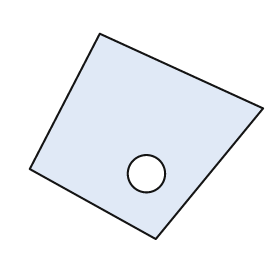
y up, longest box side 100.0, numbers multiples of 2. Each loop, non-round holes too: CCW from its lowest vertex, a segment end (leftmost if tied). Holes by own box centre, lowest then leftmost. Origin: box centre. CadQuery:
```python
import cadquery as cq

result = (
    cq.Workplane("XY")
    .moveTo(4.0, -44.0)
    .lineTo(50.0, 12.0)
    .lineTo(-20.0, 44.0)
    .lineTo(-50.0, -14.0)
    .close()
    .moveTo(0.0, -16.0)
    .circle(8.0)
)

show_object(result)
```